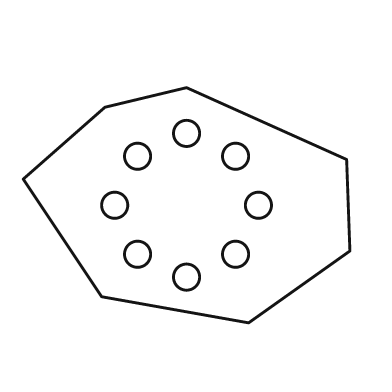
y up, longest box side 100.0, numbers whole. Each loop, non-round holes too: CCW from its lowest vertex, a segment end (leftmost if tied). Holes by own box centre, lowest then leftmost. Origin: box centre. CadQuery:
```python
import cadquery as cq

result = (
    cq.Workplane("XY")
    .moveTo(19.0, -36.0)
    .lineTo(50.0, -14.0)
    .lineTo(49.0, 14.0)
    .lineTo(0.0, 36.0)
    .lineTo(-25.0, 30.0)
    .lineTo(-50.0, 8.0)
    .lineTo(-26.0, -28.0)
    .close()
    .moveTo(0.0, -22.0)
    .circle(4.0)
    .moveTo(-15.0, -15.0)
    .circle(4.0)
    .moveTo(15.0, -15.0)
    .circle(4.0)
    .moveTo(-22.0, 0.0)
    .circle(4.0)
    .moveTo(22.0, 0.0)
    .circle(4.0)
    .moveTo(-15.0, 15.0)
    .circle(4.0)
    .moveTo(15.0, 15.0)
    .circle(4.0)
    .moveTo(0.0, 22.0)
    .circle(4.0)
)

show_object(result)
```